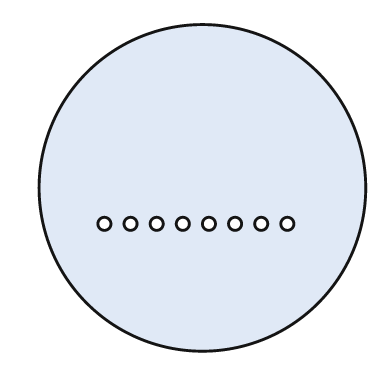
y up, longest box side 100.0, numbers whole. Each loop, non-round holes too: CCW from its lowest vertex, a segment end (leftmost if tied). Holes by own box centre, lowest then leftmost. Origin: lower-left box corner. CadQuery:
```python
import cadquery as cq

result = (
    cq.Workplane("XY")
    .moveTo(50.0, 50.0)
    .circle(50.0)
    .moveTo(20.0, 39.0)
    .circle(2.0)
    .moveTo(28.0, 39.0)
    .circle(2.0)
    .moveTo(36.0, 39.0)
    .circle(2.0)
    .moveTo(44.0, 39.0)
    .circle(2.0)
    .moveTo(52.0, 39.0)
    .circle(2.0)
    .moveTo(60.0, 39.0)
    .circle(2.0)
    .moveTo(68.0, 39.0)
    .circle(2.0)
    .moveTo(76.0, 39.0)
    .circle(2.0)
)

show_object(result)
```